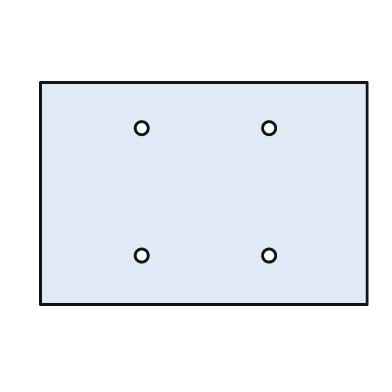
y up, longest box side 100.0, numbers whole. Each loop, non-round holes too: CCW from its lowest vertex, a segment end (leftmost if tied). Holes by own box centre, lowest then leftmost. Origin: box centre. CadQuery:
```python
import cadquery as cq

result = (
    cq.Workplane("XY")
    .moveTo(-50.0, -34.0)
    .lineTo(50.0, -34.0)
    .lineTo(50.0, 34.0)
    .lineTo(-50.0, 34.0)
    .close()
    .moveTo(-19.0, -19.0)
    .circle(2.0)
    .moveTo(20.0, -19.0)
    .circle(2.0)
    .moveTo(-19.0, 20.0)
    .circle(2.0)
    .moveTo(20.0, 20.0)
    .circle(2.0)
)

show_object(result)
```